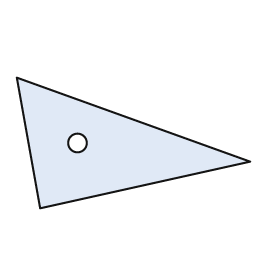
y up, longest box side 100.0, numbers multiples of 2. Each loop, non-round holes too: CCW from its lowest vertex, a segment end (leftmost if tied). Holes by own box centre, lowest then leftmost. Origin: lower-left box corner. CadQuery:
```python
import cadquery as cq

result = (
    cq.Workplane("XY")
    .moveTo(10.0, 0.0)
    .lineTo(100.0, 20.0)
    .lineTo(0.0, 56.0)
    .close()
    .moveTo(26.0, 28.0)
    .circle(4.0)
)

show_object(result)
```